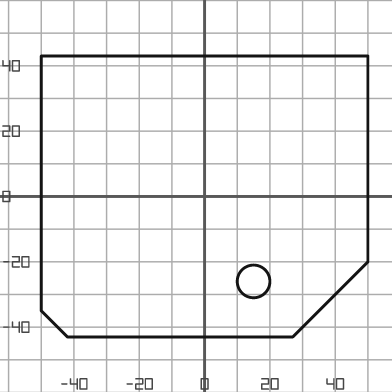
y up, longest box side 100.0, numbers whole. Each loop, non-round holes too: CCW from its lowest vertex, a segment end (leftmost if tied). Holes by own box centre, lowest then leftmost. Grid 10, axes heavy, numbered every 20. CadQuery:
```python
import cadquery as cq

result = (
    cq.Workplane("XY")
    .moveTo(-42.0, -43.0)
    .lineTo(27.0, -43.0)
    .lineTo(50.0, -20.0)
    .lineTo(50.0, 43.0)
    .lineTo(-50.0, 43.0)
    .lineTo(-50.0, -35.0)
    .close()
    .moveTo(15.0, -26.0)
    .circle(5.0)
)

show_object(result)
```